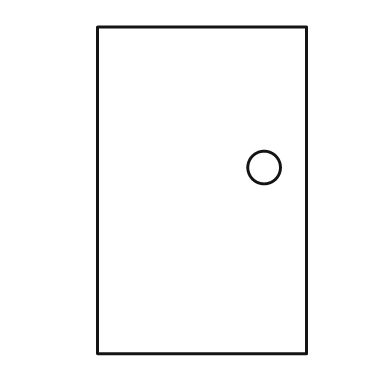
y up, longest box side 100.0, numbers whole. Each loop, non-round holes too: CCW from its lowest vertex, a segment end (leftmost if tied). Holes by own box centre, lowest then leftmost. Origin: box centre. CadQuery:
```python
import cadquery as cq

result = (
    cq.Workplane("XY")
    .moveTo(-32.0, -50.0)
    .lineTo(32.0, -50.0)
    .lineTo(32.0, 50.0)
    .lineTo(-32.0, 50.0)
    .close()
    .moveTo(19.0, 7.0)
    .circle(5.0)
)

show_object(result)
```